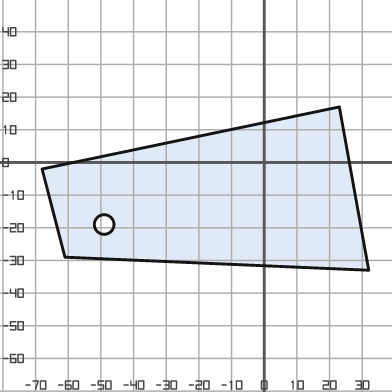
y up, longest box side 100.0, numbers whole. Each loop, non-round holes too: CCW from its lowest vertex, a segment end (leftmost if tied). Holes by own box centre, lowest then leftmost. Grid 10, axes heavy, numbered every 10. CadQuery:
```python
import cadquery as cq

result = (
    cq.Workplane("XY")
    .moveTo(32.0, -33.0)
    .lineTo(23.0, 17.0)
    .lineTo(-68.0, -2.0)
    .lineTo(-61.0, -29.0)
    .close()
    .moveTo(-49.0, -19.0)
    .circle(3.0)
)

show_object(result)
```